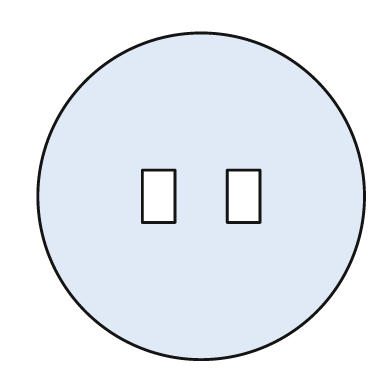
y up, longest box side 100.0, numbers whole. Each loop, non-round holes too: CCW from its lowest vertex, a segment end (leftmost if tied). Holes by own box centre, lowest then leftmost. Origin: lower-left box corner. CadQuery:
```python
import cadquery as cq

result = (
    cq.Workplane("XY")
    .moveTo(50.0, 50.0)
    .circle(50.0)
    .moveTo(32.0, 42.0)
    .lineTo(42.0, 42.0)
    .lineTo(42.0, 58.0)
    .lineTo(32.0, 58.0)
    .close()
    .moveTo(58.0, 42.0)
    .lineTo(68.0, 42.0)
    .lineTo(68.0, 58.0)
    .lineTo(58.0, 58.0)
    .close()
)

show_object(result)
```